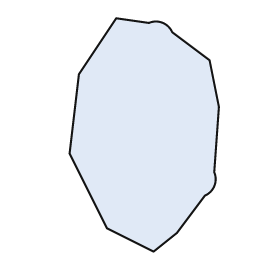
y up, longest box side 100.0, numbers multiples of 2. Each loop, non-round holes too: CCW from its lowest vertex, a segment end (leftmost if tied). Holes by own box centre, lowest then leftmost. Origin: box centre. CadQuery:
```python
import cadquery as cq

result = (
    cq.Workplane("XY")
    .moveTo(4.0, -50.0)
    .lineTo(14.0, -42.0)
    .lineTo(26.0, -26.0)
    .threePointArc((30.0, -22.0), (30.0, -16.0))
    .lineTo(32.0, 12.0)
    .lineTo(28.0, 32.0)
    .lineTo(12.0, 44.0)
    .threePointArc((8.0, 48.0), (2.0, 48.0))
    .lineTo(-12.0, 50.0)
    .lineTo(-28.0, 26.0)
    .lineTo(-32.0, -8.0)
    .lineTo(-16.0, -40.0)
    .close()
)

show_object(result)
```